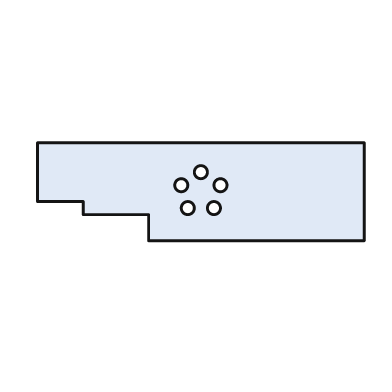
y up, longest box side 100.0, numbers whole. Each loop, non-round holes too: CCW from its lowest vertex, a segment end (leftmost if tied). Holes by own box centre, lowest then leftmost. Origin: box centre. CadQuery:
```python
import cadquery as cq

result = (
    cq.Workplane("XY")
    .moveTo(-16.0, -15.0)
    .lineTo(50.0, -15.0)
    .lineTo(50.0, 15.0)
    .lineTo(-50.0, 15.0)
    .lineTo(-50.0, -3.0)
    .lineTo(-36.0, -3.0)
    .lineTo(-36.0, -7.0)
    .lineTo(-16.0, -7.0)
    .close()
    .moveTo(-4.0, -5.0)
    .circle(2.0)
    .moveTo(4.0, -5.0)
    .circle(2.0)
    .moveTo(-6.0, 2.0)
    .circle(2.0)
    .moveTo(6.0, 2.0)
    .circle(2.0)
    .moveTo(0.0, 6.0)
    .circle(2.0)
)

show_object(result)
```